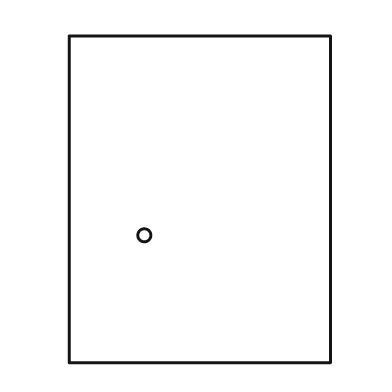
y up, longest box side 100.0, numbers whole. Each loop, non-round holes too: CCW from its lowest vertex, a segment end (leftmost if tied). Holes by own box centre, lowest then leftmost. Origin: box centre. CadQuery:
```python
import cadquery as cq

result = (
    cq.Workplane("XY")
    .moveTo(-40.0, -50.0)
    .lineTo(40.0, -50.0)
    .lineTo(40.0, 50.0)
    .lineTo(-40.0, 50.0)
    .close()
    .moveTo(-17.0, -11.0)
    .circle(2.0)
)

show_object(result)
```